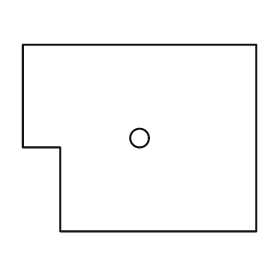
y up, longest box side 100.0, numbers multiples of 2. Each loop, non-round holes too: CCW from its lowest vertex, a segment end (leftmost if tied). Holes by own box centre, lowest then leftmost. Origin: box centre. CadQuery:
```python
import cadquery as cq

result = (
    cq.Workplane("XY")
    .moveTo(-34.0, -40.0)
    .lineTo(50.0, -40.0)
    .lineTo(50.0, 40.0)
    .lineTo(-50.0, 40.0)
    .lineTo(-50.0, -4.0)
    .lineTo(-34.0, -4.0)
    .close()
    .moveTo(0.0, 0.0)
    .circle(4.0)
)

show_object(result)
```